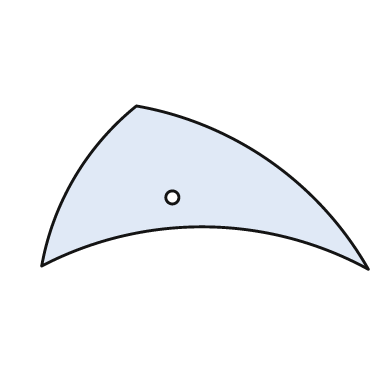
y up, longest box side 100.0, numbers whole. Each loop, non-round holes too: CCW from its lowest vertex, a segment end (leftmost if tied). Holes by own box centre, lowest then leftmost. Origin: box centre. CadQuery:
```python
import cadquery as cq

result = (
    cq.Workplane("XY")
    .moveTo(50.0, -25.0)
    .threePointArc((20.0, 8.0), (-21.0, 25.0))
    .threePointArc((-40.0, 3.0), (-50.0, -24.0))
    .threePointArc((0.0, -12.0), (50.0, -25.0))
    .close()
    .moveTo(-10.0, -3.0)
    .circle(2.0)
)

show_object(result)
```